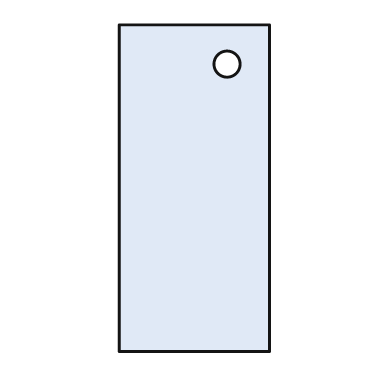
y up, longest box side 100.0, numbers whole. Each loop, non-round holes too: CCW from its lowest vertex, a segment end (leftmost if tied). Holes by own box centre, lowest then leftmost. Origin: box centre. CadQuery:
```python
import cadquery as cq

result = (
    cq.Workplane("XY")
    .moveTo(-23.0, -50.0)
    .lineTo(23.0, -50.0)
    .lineTo(23.0, 50.0)
    .lineTo(-23.0, 50.0)
    .close()
    .moveTo(10.0, 38.0)
    .circle(4.0)
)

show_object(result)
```